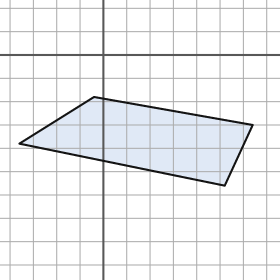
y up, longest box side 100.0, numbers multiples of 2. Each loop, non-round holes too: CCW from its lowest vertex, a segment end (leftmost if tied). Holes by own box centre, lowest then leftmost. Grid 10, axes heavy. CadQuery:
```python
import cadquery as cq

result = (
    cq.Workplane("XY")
    .moveTo(52.0, -56.0)
    .lineTo(64.0, -30.0)
    .lineTo(-4.0, -18.0)
    .lineTo(-36.0, -38.0)
    .close()
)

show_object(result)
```